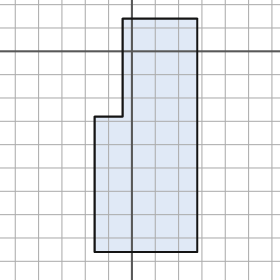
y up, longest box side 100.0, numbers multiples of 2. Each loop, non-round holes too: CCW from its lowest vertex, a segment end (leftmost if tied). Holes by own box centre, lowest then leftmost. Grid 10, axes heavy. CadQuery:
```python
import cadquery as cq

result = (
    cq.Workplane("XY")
    .moveTo(-16.0, -86.0)
    .lineTo(28.0, -86.0)
    .lineTo(28.0, 14.0)
    .lineTo(-4.0, 14.0)
    .lineTo(-4.0, -28.0)
    .lineTo(-16.0, -28.0)
    .close()
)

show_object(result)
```